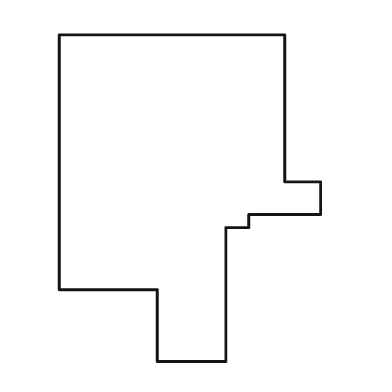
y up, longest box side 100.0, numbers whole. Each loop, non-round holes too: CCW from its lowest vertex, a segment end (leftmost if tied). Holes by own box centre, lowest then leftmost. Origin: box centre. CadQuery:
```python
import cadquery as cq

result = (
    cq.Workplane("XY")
    .moveTo(-10.0, -50.0)
    .lineTo(11.0, -50.0)
    .lineTo(11.0, -9.0)
    .lineTo(18.0, -9.0)
    .lineTo(18.0, -5.0)
    .lineTo(40.0, -5.0)
    .lineTo(40.0, 5.0)
    .lineTo(29.0, 5.0)
    .lineTo(29.0, 50.0)
    .lineTo(-40.0, 50.0)
    .lineTo(-40.0, -28.0)
    .lineTo(-10.0, -28.0)
    .close()
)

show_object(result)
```